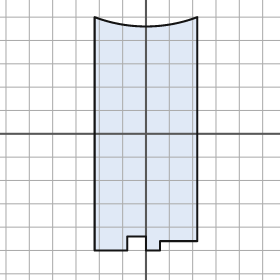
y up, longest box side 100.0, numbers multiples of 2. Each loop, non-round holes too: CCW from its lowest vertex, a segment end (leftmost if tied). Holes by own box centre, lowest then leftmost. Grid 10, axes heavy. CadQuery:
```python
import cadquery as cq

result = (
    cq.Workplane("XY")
    .moveTo(-22.0, -50.0)
    .lineTo(-8.0, -50.0)
    .lineTo(-8.0, -44.0)
    .lineTo(0.0, -44.0)
    .lineTo(0.0, -50.0)
    .lineTo(6.0, -50.0)
    .lineTo(6.0, -46.0)
    .lineTo(22.0, -46.0)
    .lineTo(22.0, 50.0)
    .threePointArc((0.0, 46.0), (-22.0, 50.0))
    .close()
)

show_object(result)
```